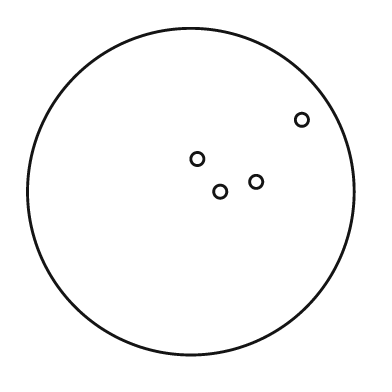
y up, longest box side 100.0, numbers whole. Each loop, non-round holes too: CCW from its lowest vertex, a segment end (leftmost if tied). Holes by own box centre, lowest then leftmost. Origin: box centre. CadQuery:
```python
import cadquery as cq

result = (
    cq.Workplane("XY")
    .moveTo(0.0, 0.0)
    .circle(50.0)
    .moveTo(9.0, 0.0)
    .circle(2.0)
    .moveTo(20.0, 3.0)
    .circle(2.0)
    .moveTo(2.0, 10.0)
    .circle(2.0)
    .moveTo(34.0, 22.0)
    .circle(2.0)
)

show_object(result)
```